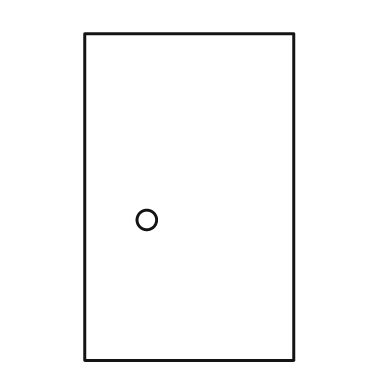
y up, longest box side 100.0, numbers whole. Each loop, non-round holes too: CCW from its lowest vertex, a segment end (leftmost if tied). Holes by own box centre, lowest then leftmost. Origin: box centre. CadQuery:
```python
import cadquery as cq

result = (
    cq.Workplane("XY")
    .moveTo(-32.0, -50.0)
    .lineTo(32.0, -50.0)
    .lineTo(32.0, 50.0)
    .lineTo(-32.0, 50.0)
    .close()
    .moveTo(-13.0, -7.0)
    .circle(3.0)
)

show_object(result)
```